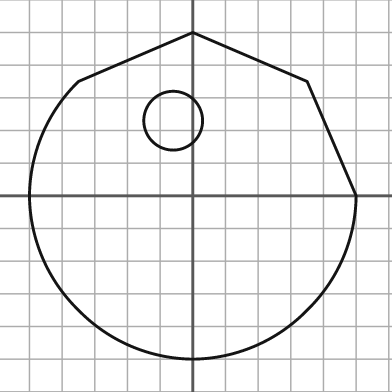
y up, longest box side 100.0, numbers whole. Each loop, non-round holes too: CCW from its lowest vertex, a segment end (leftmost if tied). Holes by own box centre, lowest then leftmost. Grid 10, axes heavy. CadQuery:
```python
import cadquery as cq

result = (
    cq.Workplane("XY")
    .moveTo(0.0, -50.0)
    .threePointArc((19.0, -46.0), (35.0, -35.0))
    .threePointArc((46.0, -19.0), (50.0, 0.0))
    .lineTo(35.0, 35.0)
    .lineTo(0.0, 50.0)
    .lineTo(-35.0, 35.0)
    .threePointArc((-46.0, 19.0), (-50.0, 0.0))
    .threePointArc((-46.0, -19.0), (-35.0, -35.0))
    .threePointArc((-19.0, -46.0), (0.0, -50.0))
    .close()
    .moveTo(-6.0, 23.0)
    .circle(9.0)
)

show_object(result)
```